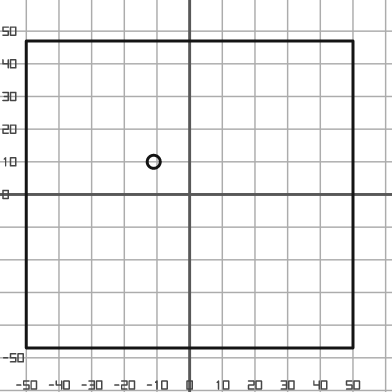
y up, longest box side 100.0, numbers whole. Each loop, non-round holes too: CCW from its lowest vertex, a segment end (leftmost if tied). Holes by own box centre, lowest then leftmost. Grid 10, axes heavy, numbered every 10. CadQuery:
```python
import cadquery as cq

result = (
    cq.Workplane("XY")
    .moveTo(-50.0, -47.0)
    .lineTo(50.0, -47.0)
    .lineTo(50.0, 47.0)
    .lineTo(-50.0, 47.0)
    .close()
    .moveTo(-11.0, 10.0)
    .circle(2.0)
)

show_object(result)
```